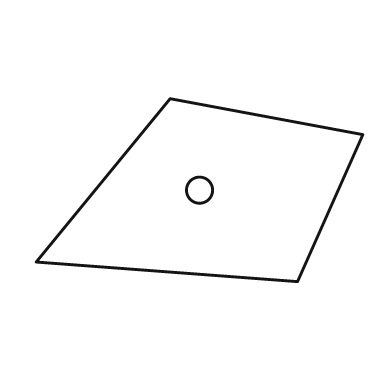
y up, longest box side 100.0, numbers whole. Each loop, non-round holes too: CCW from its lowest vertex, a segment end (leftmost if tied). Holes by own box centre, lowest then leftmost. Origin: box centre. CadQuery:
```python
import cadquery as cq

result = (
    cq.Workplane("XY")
    .moveTo(30.0, -28.0)
    .lineTo(50.0, 17.0)
    .lineTo(-9.0, 28.0)
    .lineTo(-50.0, -22.0)
    .close()
    .moveTo(0.0, 0.0)
    .circle(4.0)
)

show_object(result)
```